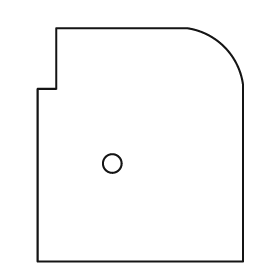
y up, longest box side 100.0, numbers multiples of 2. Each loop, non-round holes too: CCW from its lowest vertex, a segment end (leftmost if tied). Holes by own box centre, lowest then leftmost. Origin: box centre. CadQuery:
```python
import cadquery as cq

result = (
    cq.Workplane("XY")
    .moveTo(-44.0, -50.0)
    .lineTo(44.0, -50.0)
    .lineTo(44.0, 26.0)
    .threePointArc((36.0, 42.0), (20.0, 50.0))
    .lineTo(-36.0, 50.0)
    .lineTo(-36.0, 24.0)
    .lineTo(-44.0, 24.0)
    .close()
    .moveTo(-12.0, -8.0)
    .circle(4.0)
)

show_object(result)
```